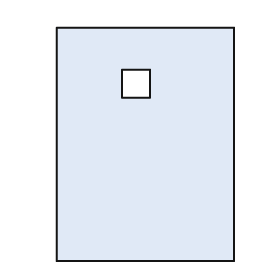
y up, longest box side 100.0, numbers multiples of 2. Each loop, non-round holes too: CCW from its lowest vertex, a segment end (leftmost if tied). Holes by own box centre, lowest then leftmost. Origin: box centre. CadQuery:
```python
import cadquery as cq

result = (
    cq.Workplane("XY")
    .moveTo(-38.0, -50.0)
    .lineTo(38.0, -50.0)
    .lineTo(38.0, 50.0)
    .lineTo(-38.0, 50.0)
    .close()
    .moveTo(-10.0, 20.0)
    .lineTo(2.0, 20.0)
    .lineTo(2.0, 32.0)
    .lineTo(-10.0, 32.0)
    .close()
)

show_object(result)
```